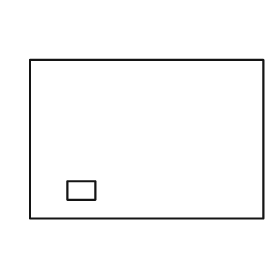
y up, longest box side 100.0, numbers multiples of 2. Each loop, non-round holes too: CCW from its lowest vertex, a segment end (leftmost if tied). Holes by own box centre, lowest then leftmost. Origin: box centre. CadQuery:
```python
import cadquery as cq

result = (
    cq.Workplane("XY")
    .moveTo(-50.0, -34.0)
    .lineTo(50.0, -34.0)
    .lineTo(50.0, 34.0)
    .lineTo(-50.0, 34.0)
    .close()
    .moveTo(-34.0, -26.0)
    .lineTo(-22.0, -26.0)
    .lineTo(-22.0, -18.0)
    .lineTo(-34.0, -18.0)
    .close()
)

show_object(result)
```